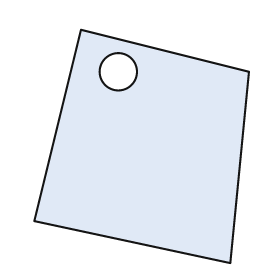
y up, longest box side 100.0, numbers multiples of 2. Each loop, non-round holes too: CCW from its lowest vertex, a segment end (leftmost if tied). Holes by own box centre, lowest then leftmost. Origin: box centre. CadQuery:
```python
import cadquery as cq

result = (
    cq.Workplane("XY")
    .moveTo(38.0, -50.0)
    .lineTo(46.0, 32.0)
    .lineTo(-26.0, 50.0)
    .lineTo(-46.0, -32.0)
    .close()
    .moveTo(-10.0, 32.0)
    .circle(8.0)
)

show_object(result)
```